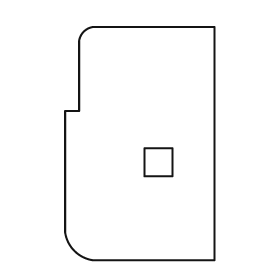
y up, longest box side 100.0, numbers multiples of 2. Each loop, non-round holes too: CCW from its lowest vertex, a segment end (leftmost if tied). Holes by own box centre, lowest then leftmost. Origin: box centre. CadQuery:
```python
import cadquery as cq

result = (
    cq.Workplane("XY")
    .moveTo(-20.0, -50.0)
    .lineTo(32.0, -50.0)
    .lineTo(32.0, 50.0)
    .lineTo(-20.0, 50.0)
    .threePointArc((-24.0, 48.0), (-26.0, 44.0))
    .lineTo(-26.0, 14.0)
    .lineTo(-32.0, 14.0)
    .lineTo(-32.0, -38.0)
    .threePointArc((-28.0, -46.0), (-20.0, -50.0))
    .close()
    .moveTo(2.0, -14.0)
    .lineTo(14.0, -14.0)
    .lineTo(14.0, -2.0)
    .lineTo(2.0, -2.0)
    .close()
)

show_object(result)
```